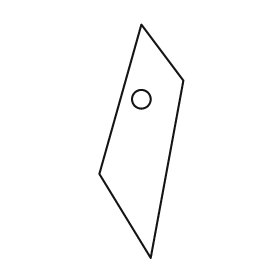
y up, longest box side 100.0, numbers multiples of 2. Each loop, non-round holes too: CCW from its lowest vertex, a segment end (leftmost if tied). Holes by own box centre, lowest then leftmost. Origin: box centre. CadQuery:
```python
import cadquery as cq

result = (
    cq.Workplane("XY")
    .moveTo(4.0, -50.0)
    .lineTo(18.0, 26.0)
    .lineTo(0.0, 50.0)
    .lineTo(-18.0, -14.0)
    .close()
    .moveTo(0.0, 18.0)
    .circle(4.0)
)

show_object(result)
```